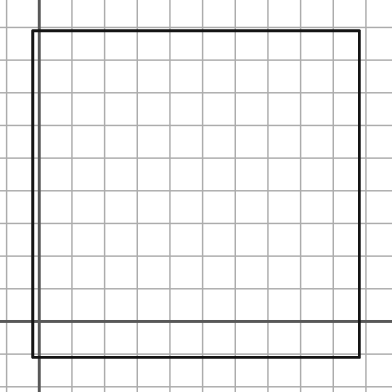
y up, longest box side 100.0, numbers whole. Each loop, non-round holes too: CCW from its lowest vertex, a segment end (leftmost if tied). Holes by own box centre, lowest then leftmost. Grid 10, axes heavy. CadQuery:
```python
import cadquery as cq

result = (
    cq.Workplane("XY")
    .moveTo(-2.0, -11.0)
    .lineTo(98.0, -11.0)
    .lineTo(98.0, 89.0)
    .lineTo(-2.0, 89.0)
    .close()
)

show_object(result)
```